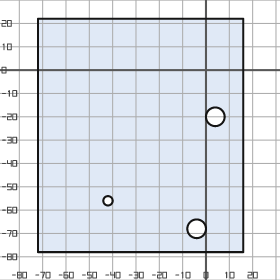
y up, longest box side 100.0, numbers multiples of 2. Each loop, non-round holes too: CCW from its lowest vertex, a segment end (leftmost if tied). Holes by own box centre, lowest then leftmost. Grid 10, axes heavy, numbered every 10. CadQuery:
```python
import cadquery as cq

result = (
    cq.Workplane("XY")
    .moveTo(-72.0, -78.0)
    .lineTo(16.0, -78.0)
    .lineTo(16.0, 22.0)
    .lineTo(-72.0, 22.0)
    .close()
    .moveTo(-4.0, -68.0)
    .circle(4.0)
    .moveTo(-42.0, -56.0)
    .circle(2.0)
    .moveTo(4.0, -20.0)
    .circle(4.0)
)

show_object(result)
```